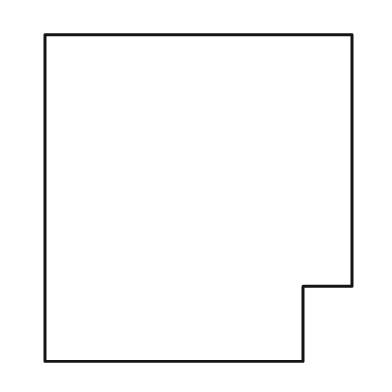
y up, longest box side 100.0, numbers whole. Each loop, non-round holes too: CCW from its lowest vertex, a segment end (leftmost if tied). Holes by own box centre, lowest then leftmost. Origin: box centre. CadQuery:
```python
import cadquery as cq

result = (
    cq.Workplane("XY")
    .moveTo(-47.0, -50.0)
    .lineTo(32.0, -50.0)
    .lineTo(32.0, -27.0)
    .lineTo(47.0, -27.0)
    .lineTo(47.0, 50.0)
    .lineTo(-47.0, 50.0)
    .close()
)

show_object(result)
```